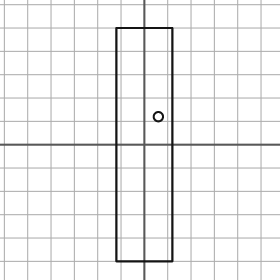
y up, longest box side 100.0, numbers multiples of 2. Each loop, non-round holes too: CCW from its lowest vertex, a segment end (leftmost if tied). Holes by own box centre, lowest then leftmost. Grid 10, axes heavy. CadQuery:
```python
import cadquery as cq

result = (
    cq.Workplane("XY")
    .moveTo(-12.0, -50.0)
    .lineTo(12.0, -50.0)
    .lineTo(12.0, 50.0)
    .lineTo(-12.0, 50.0)
    .close()
    .moveTo(6.0, 12.0)
    .circle(2.0)
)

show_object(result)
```